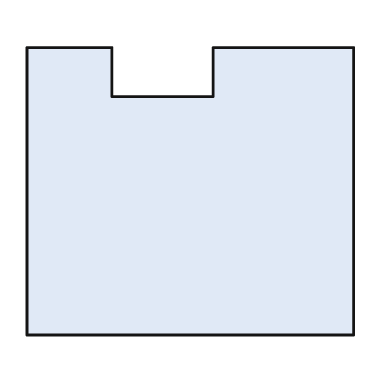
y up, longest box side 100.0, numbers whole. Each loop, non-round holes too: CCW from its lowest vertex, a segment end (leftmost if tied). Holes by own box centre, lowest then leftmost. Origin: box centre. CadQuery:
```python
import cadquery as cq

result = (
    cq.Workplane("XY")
    .moveTo(-50.0, -44.0)
    .lineTo(50.0, -44.0)
    .lineTo(50.0, 44.0)
    .lineTo(7.0, 44.0)
    .lineTo(7.0, 29.0)
    .lineTo(-24.0, 29.0)
    .lineTo(-24.0, 44.0)
    .lineTo(-50.0, 44.0)
    .close()
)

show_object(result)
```